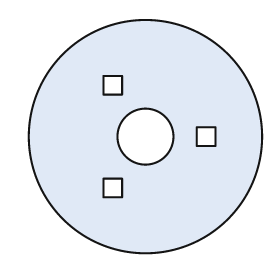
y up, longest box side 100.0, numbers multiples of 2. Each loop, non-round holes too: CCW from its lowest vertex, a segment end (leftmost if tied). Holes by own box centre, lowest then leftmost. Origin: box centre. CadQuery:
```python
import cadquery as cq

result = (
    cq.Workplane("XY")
    .moveTo(0.0, 0.0)
    .circle(50.0)
    .moveTo(-18.0, -26.0)
    .lineTo(-10.0, -26.0)
    .lineTo(-10.0, -18.0)
    .lineTo(-18.0, -18.0)
    .close()
    .moveTo(0.0, 0.0)
    .circle(12.0)
    .moveTo(22.0, -4.0)
    .lineTo(30.0, -4.0)
    .lineTo(30.0, 4.0)
    .lineTo(22.0, 4.0)
    .close()
    .moveTo(-18.0, 18.0)
    .lineTo(-10.0, 18.0)
    .lineTo(-10.0, 26.0)
    .lineTo(-18.0, 26.0)
    .close()
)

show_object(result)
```